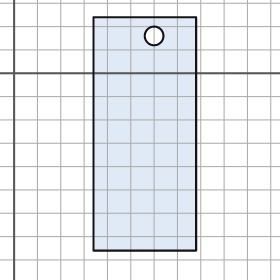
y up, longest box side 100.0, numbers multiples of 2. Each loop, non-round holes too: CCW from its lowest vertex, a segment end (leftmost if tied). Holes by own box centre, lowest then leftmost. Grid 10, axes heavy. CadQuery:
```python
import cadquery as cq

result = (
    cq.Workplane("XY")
    .moveTo(34.0, -76.0)
    .lineTo(78.0, -76.0)
    .lineTo(78.0, 24.0)
    .lineTo(34.0, 24.0)
    .close()
    .moveTo(60.0, 16.0)
    .circle(4.0)
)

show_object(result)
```